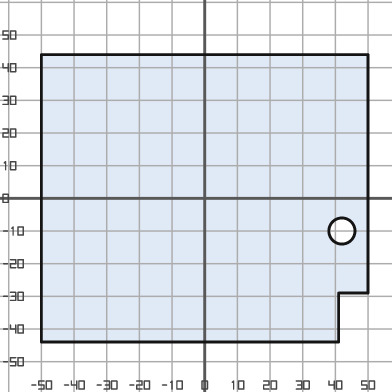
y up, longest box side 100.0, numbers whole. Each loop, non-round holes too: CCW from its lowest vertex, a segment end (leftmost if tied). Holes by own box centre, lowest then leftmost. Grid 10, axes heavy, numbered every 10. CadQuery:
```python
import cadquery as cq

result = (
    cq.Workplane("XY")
    .moveTo(-50.0, -44.0)
    .lineTo(41.0, -44.0)
    .lineTo(41.0, -29.0)
    .lineTo(50.0, -29.0)
    .lineTo(50.0, 44.0)
    .lineTo(-50.0, 44.0)
    .close()
    .moveTo(42.0, -10.0)
    .circle(4.0)
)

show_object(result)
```